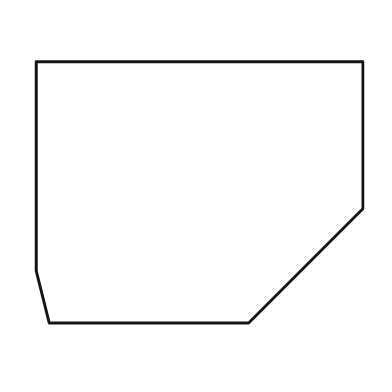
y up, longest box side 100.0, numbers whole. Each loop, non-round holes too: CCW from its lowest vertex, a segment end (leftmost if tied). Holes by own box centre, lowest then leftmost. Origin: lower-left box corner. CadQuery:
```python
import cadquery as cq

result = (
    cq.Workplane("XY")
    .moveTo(4.0, 0.0)
    .lineTo(65.0, 0.0)
    .lineTo(100.0, 35.0)
    .lineTo(100.0, 80.0)
    .lineTo(0.0, 80.0)
    .lineTo(0.0, 16.0)
    .close()
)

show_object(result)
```